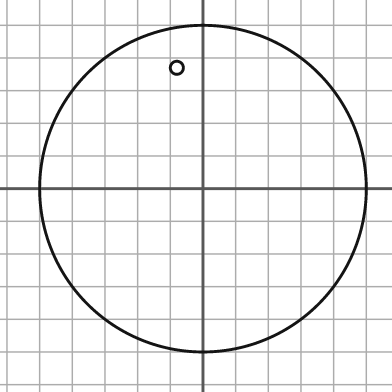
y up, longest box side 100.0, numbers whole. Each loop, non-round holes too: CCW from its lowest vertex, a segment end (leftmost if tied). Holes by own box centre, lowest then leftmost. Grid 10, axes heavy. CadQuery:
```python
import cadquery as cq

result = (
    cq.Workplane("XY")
    .moveTo(0.0, 0.0)
    .circle(50.0)
    .moveTo(-8.0, 37.0)
    .circle(2.0)
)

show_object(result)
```